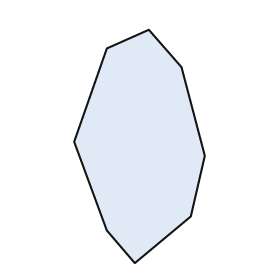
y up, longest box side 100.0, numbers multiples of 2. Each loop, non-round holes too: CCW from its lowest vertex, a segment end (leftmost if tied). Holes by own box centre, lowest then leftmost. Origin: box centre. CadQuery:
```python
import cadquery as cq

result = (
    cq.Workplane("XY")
    .moveTo(-2.0, -50.0)
    .lineTo(22.0, -30.0)
    .lineTo(28.0, -4.0)
    .lineTo(18.0, 34.0)
    .lineTo(4.0, 50.0)
    .lineTo(-14.0, 42.0)
    .lineTo(-28.0, 2.0)
    .lineTo(-14.0, -36.0)
    .close()
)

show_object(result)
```